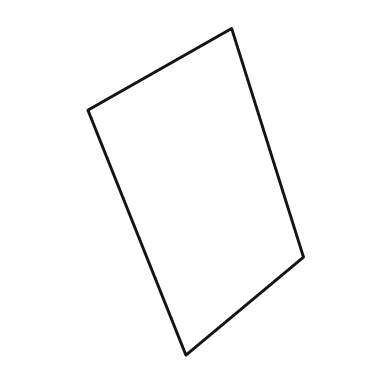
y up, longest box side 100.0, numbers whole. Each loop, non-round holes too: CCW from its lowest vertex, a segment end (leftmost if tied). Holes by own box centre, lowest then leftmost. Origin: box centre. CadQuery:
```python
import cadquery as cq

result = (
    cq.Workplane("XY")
    .moveTo(-3.0, -50.0)
    .lineTo(33.0, -20.0)
    .lineTo(11.0, 50.0)
    .lineTo(-33.0, 25.0)
    .close()
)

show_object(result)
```